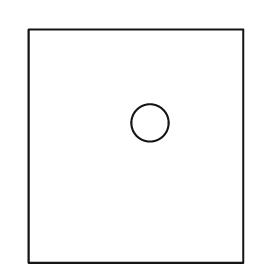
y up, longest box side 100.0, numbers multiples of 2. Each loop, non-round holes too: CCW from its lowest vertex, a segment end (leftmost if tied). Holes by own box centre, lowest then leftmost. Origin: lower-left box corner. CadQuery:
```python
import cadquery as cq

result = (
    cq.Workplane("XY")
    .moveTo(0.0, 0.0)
    .lineTo(92.0, 0.0)
    .lineTo(92.0, 100.0)
    .lineTo(0.0, 100.0)
    .close()
    .moveTo(52.0, 60.0)
    .circle(8.0)
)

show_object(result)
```